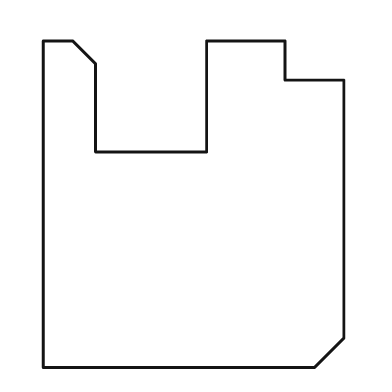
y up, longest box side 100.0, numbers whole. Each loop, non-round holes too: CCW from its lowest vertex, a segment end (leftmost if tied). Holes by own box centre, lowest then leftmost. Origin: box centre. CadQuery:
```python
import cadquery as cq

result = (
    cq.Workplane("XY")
    .moveTo(-46.0, -50.0)
    .lineTo(37.0, -50.0)
    .lineTo(46.0, -41.0)
    .lineTo(46.0, 38.0)
    .lineTo(28.0, 38.0)
    .lineTo(28.0, 50.0)
    .lineTo(4.0, 50.0)
    .lineTo(4.0, 16.0)
    .lineTo(-30.0, 16.0)
    .lineTo(-30.0, 43.0)
    .lineTo(-37.0, 50.0)
    .lineTo(-46.0, 50.0)
    .close()
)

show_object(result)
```